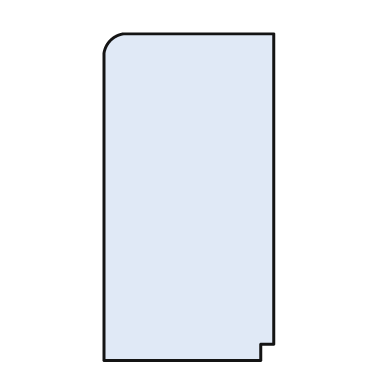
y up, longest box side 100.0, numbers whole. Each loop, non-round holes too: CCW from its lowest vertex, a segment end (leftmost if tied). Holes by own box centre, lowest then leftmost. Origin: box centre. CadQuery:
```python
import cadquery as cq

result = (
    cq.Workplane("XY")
    .moveTo(-26.0, -50.0)
    .lineTo(22.0, -50.0)
    .lineTo(22.0, -45.0)
    .lineTo(26.0, -45.0)
    .lineTo(26.0, 50.0)
    .lineTo(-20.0, 50.0)
    .threePointArc((-24.0, 48.0), (-26.0, 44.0))
    .close()
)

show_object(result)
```